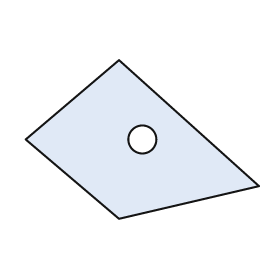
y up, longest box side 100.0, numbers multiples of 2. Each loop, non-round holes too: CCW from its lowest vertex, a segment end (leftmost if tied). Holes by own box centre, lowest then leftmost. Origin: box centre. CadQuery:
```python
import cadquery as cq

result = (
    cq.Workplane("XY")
    .moveTo(-10.0, -34.0)
    .lineTo(50.0, -20.0)
    .lineTo(-10.0, 34.0)
    .lineTo(-50.0, 0.0)
    .close()
    .moveTo(0.0, 0.0)
    .circle(6.0)
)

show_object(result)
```